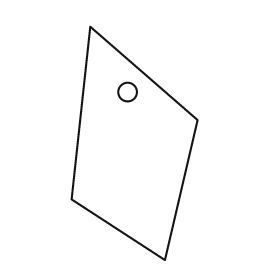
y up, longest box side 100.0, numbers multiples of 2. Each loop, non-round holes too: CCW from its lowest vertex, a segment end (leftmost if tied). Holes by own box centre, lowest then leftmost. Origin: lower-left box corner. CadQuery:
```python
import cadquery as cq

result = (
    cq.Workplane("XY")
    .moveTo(40.0, 0.0)
    .lineTo(54.0, 60.0)
    .lineTo(8.0, 100.0)
    .lineTo(0.0, 26.0)
    .close()
    .moveTo(24.0, 72.0)
    .circle(4.0)
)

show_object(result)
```